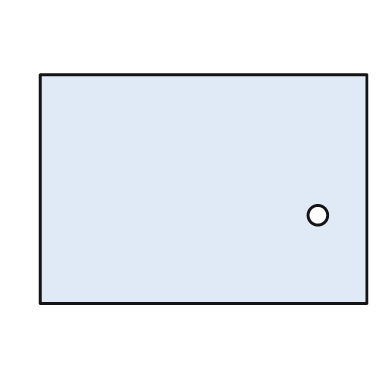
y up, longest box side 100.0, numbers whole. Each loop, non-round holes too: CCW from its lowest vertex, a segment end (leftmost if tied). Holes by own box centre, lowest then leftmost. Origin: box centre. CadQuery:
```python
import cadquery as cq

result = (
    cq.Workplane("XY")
    .moveTo(-50.0, -35.0)
    .lineTo(50.0, -35.0)
    .lineTo(50.0, 35.0)
    .lineTo(-50.0, 35.0)
    .close()
    .moveTo(35.0, -8.0)
    .circle(3.0)
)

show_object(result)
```